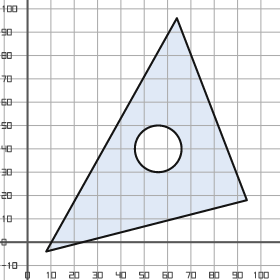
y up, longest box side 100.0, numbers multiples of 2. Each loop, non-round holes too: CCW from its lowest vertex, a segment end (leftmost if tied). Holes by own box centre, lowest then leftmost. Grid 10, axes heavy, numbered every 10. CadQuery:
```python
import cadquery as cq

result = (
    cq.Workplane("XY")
    .moveTo(8.0, -4.0)
    .lineTo(94.0, 18.0)
    .lineTo(64.0, 96.0)
    .close()
    .moveTo(56.0, 40.0)
    .circle(10.0)
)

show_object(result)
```